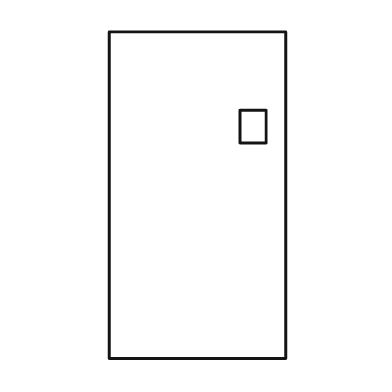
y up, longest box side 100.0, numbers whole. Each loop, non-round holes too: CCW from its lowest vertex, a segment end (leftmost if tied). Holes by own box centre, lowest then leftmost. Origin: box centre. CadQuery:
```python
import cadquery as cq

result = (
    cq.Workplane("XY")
    .moveTo(-27.0, -50.0)
    .lineTo(27.0, -50.0)
    .lineTo(27.0, 50.0)
    .lineTo(-27.0, 50.0)
    .close()
    .moveTo(13.0, 16.0)
    .lineTo(21.0, 16.0)
    .lineTo(21.0, 26.0)
    .lineTo(13.0, 26.0)
    .close()
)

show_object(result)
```